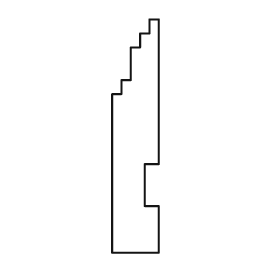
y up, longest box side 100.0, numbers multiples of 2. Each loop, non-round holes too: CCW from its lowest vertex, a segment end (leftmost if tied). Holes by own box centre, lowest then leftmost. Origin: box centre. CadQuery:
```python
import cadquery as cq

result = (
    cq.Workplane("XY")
    .moveTo(-10.0, -50.0)
    .lineTo(10.0, -50.0)
    .lineTo(10.0, -30.0)
    .lineTo(4.0, -30.0)
    .lineTo(4.0, -12.0)
    .lineTo(10.0, -12.0)
    .lineTo(10.0, 50.0)
    .lineTo(6.0, 50.0)
    .lineTo(6.0, 44.0)
    .lineTo(2.0, 44.0)
    .lineTo(2.0, 38.0)
    .lineTo(-2.0, 38.0)
    .lineTo(-2.0, 24.0)
    .lineTo(-6.0, 24.0)
    .lineTo(-6.0, 18.0)
    .lineTo(-10.0, 18.0)
    .close()
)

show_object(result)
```